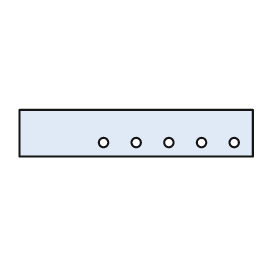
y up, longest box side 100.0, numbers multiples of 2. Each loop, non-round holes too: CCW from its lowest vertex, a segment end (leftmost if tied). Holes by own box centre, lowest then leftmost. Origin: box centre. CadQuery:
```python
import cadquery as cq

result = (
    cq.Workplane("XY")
    .moveTo(-50.0, -10.0)
    .lineTo(50.0, -10.0)
    .lineTo(50.0, 10.0)
    .lineTo(-50.0, 10.0)
    .close()
    .moveTo(-14.0, -4.0)
    .circle(2.0)
    .moveTo(0.0, -4.0)
    .circle(2.0)
    .moveTo(14.0, -4.0)
    .circle(2.0)
    .moveTo(28.0, -4.0)
    .circle(2.0)
    .moveTo(42.0, -4.0)
    .circle(2.0)
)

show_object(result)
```